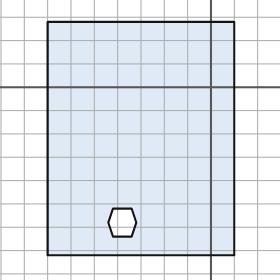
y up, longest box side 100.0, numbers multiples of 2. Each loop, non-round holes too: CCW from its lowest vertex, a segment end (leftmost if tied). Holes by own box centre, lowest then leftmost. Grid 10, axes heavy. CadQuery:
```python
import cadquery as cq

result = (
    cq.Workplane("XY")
    .moveTo(-70.0, -72.0)
    .lineTo(10.0, -72.0)
    .lineTo(10.0, 28.0)
    .lineTo(-70.0, 28.0)
    .close()
    .moveTo(-42.0, -64.0)
    .lineTo(-34.0, -64.0)
    .lineTo(-32.0, -58.0)
    .lineTo(-34.0, -52.0)
    .lineTo(-42.0, -52.0)
    .lineTo(-44.0, -58.0)
    .close()
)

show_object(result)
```